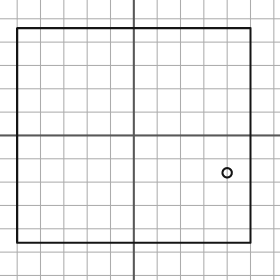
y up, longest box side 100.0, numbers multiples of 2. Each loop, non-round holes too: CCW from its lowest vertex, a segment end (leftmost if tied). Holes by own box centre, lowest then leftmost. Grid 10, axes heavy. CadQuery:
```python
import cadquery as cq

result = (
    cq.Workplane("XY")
    .moveTo(-50.0, -46.0)
    .lineTo(50.0, -46.0)
    .lineTo(50.0, 46.0)
    .lineTo(-50.0, 46.0)
    .close()
    .moveTo(40.0, -16.0)
    .circle(2.0)
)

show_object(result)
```